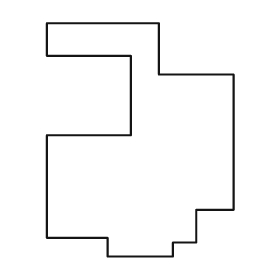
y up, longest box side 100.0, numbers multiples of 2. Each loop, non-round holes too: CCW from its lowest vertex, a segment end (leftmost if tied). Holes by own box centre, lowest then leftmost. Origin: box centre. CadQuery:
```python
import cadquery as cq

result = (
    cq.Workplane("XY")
    .moveTo(-14.0, -50.0)
    .lineTo(14.0, -50.0)
    .lineTo(14.0, -44.0)
    .lineTo(24.0, -44.0)
    .lineTo(24.0, -30.0)
    .lineTo(40.0, -30.0)
    .lineTo(40.0, 28.0)
    .lineTo(8.0, 28.0)
    .lineTo(8.0, 50.0)
    .lineTo(-40.0, 50.0)
    .lineTo(-40.0, 36.0)
    .lineTo(-4.0, 36.0)
    .lineTo(-4.0, 2.0)
    .lineTo(-40.0, 2.0)
    .lineTo(-40.0, -42.0)
    .lineTo(-14.0, -42.0)
    .close()
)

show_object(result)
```